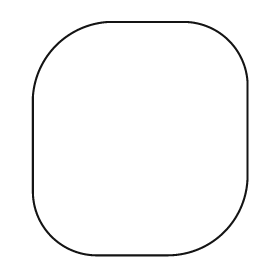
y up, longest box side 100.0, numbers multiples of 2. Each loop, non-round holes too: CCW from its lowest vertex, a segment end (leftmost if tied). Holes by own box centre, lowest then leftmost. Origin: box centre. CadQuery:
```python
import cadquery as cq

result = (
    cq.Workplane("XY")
    .moveTo(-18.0, -50.0)
    .lineTo(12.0, -50.0)
    .threePointArc((36.0, -40.0), (46.0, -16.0))
    .lineTo(46.0, 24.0)
    .threePointArc((38.0, 42.0), (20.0, 50.0))
    .lineTo(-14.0, 50.0)
    .threePointArc((-36.0, 40.0), (-46.0, 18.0))
    .lineTo(-46.0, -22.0)
    .threePointArc((-38.0, -42.0), (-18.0, -50.0))
    .close()
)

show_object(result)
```